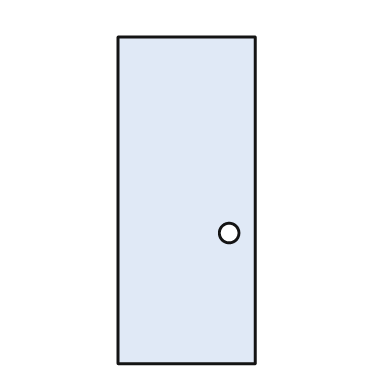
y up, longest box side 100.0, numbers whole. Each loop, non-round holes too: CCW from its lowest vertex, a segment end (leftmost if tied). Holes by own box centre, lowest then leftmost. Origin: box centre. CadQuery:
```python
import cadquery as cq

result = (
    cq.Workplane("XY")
    .moveTo(-21.0, -50.0)
    .lineTo(21.0, -50.0)
    .lineTo(21.0, 50.0)
    .lineTo(-21.0, 50.0)
    .close()
    .moveTo(13.0, -10.0)
    .circle(3.0)
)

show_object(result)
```